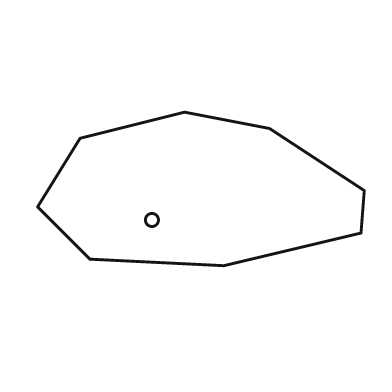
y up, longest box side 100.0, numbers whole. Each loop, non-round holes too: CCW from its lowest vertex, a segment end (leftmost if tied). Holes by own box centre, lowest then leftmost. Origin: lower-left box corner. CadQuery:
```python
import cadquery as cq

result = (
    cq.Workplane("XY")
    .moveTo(57.0, 0.0)
    .lineTo(99.0, 10.0)
    .lineTo(100.0, 23.0)
    .lineTo(71.0, 42.0)
    .lineTo(45.0, 47.0)
    .lineTo(13.0, 39.0)
    .lineTo(0.0, 18.0)
    .lineTo(16.0, 2.0)
    .close()
    .moveTo(35.0, 14.0)
    .circle(2.0)
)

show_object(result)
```